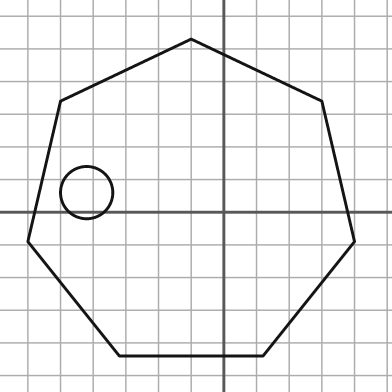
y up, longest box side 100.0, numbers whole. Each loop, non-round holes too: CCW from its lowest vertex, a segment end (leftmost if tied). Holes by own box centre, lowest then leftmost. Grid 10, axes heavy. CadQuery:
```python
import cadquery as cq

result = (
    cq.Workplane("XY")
    .moveTo(-32.0, -44.0)
    .lineTo(12.0, -44.0)
    .lineTo(40.0, -9.0)
    .lineTo(30.0, 34.0)
    .lineTo(-10.0, 53.0)
    .lineTo(-50.0, 34.0)
    .lineTo(-60.0, -9.0)
    .close()
    .moveTo(-42.0, 6.0)
    .circle(8.0)
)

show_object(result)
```